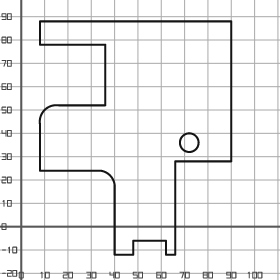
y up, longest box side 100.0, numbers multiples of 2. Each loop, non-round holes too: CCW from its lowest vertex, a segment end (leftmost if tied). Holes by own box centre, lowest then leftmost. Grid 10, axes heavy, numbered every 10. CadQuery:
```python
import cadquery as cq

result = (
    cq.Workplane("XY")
    .moveTo(40.0, -12.0)
    .lineTo(48.0, -12.0)
    .lineTo(48.0, -6.0)
    .lineTo(62.0, -6.0)
    .lineTo(62.0, -12.0)
    .lineTo(66.0, -12.0)
    .lineTo(66.0, 28.0)
    .lineTo(90.0, 28.0)
    .lineTo(90.0, 88.0)
    .lineTo(8.0, 88.0)
    .lineTo(8.0, 78.0)
    .lineTo(36.0, 78.0)
    .lineTo(36.0, 52.0)
    .lineTo(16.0, 52.0)
    .threePointArc((10.0, 50.0), (8.0, 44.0))
    .lineTo(8.0, 24.0)
    .lineTo(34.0, 24.0)
    .threePointArc((38.0, 22.0), (40.0, 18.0))
    .close()
    .moveTo(72.0, 36.0)
    .circle(4.0)
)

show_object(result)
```